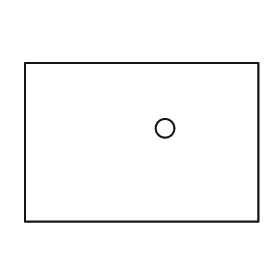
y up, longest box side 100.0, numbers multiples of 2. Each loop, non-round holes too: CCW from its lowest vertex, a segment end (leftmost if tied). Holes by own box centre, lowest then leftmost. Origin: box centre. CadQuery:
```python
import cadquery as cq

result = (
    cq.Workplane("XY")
    .moveTo(-50.0, -34.0)
    .lineTo(50.0, -34.0)
    .lineTo(50.0, 34.0)
    .lineTo(-50.0, 34.0)
    .close()
    .moveTo(10.0, 6.0)
    .circle(4.0)
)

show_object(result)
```